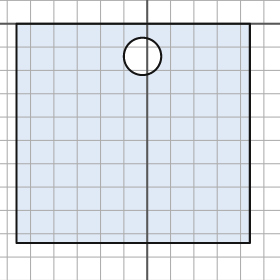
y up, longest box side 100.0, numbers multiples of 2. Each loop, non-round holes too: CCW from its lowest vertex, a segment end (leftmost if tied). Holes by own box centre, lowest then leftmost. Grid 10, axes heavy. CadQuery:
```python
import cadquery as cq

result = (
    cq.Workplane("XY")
    .moveTo(-56.0, -94.0)
    .lineTo(44.0, -94.0)
    .lineTo(44.0, 0.0)
    .lineTo(-56.0, 0.0)
    .close()
    .moveTo(-2.0, -14.0)
    .circle(8.0)
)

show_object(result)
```